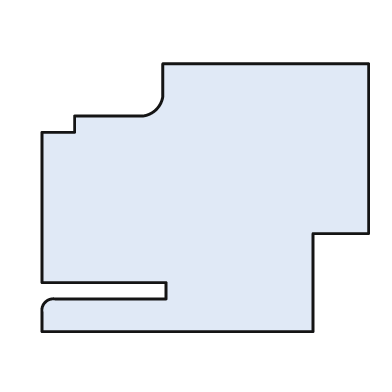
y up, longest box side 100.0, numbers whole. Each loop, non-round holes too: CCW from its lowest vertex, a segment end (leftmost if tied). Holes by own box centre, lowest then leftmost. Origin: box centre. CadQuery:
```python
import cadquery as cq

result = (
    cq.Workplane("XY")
    .moveTo(-50.0, -41.0)
    .lineTo(33.0, -41.0)
    .lineTo(33.0, -11.0)
    .lineTo(50.0, -11.0)
    .lineTo(50.0, 41.0)
    .lineTo(-13.0, 41.0)
    .lineTo(-13.0, 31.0)
    .threePointArc((-15.0, 27.0), (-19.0, 25.0))
    .lineTo(-40.0, 25.0)
    .lineTo(-40.0, 20.0)
    .lineTo(-50.0, 20.0)
    .lineTo(-50.0, -26.0)
    .lineTo(-12.0, -26.0)
    .lineTo(-12.0, -31.0)
    .lineTo(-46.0, -31.0)
    .threePointArc((-49.0, -32.0), (-50.0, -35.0))
    .close()
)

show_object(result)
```